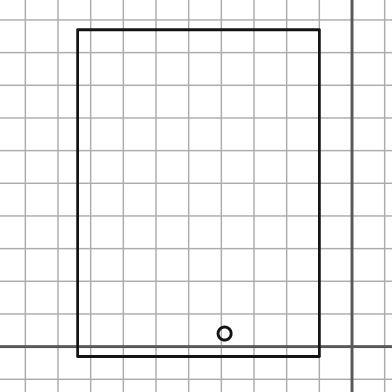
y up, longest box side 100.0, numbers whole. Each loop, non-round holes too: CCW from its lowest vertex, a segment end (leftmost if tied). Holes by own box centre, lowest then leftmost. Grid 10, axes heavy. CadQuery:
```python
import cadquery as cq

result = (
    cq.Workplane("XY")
    .moveTo(-84.0, -3.0)
    .lineTo(-10.0, -3.0)
    .lineTo(-10.0, 97.0)
    .lineTo(-84.0, 97.0)
    .close()
    .moveTo(-39.0, 4.0)
    .circle(2.0)
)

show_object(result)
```